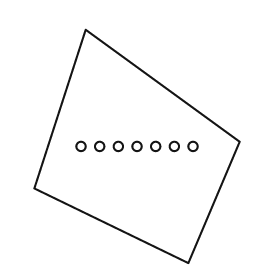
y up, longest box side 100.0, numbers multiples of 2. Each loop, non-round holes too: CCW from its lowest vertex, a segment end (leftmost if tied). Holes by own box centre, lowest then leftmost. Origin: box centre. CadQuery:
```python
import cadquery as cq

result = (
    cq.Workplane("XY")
    .moveTo(22.0, -50.0)
    .lineTo(44.0, 2.0)
    .lineTo(-22.0, 50.0)
    .lineTo(-44.0, -18.0)
    .close()
    .moveTo(-24.0, 0.0)
    .circle(2.0)
    .moveTo(-16.0, 0.0)
    .circle(2.0)
    .moveTo(-8.0, 0.0)
    .circle(2.0)
    .moveTo(0.0, 0.0)
    .circle(2.0)
    .moveTo(8.0, 0.0)
    .circle(2.0)
    .moveTo(16.0, 0.0)
    .circle(2.0)
    .moveTo(24.0, 0.0)
    .circle(2.0)
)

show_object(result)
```